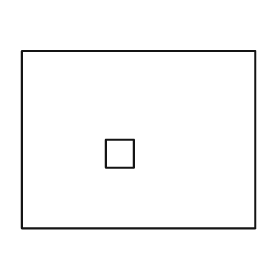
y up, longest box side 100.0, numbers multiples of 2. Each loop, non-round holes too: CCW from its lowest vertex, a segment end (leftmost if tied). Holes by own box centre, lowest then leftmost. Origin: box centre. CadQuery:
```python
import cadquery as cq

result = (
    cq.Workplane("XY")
    .moveTo(-50.0, -38.0)
    .lineTo(50.0, -38.0)
    .lineTo(50.0, 38.0)
    .lineTo(-50.0, 38.0)
    .close()
    .moveTo(-14.0, -12.0)
    .lineTo(-2.0, -12.0)
    .lineTo(-2.0, 0.0)
    .lineTo(-14.0, 0.0)
    .close()
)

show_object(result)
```